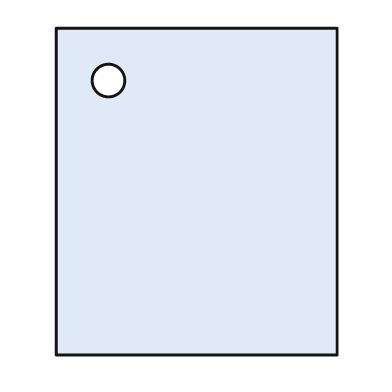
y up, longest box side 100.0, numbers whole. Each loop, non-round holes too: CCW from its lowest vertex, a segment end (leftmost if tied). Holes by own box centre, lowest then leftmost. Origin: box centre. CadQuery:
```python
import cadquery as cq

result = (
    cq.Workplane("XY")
    .moveTo(-43.0, -50.0)
    .lineTo(43.0, -50.0)
    .lineTo(43.0, 50.0)
    .lineTo(-43.0, 50.0)
    .close()
    .moveTo(-27.0, 34.0)
    .circle(5.0)
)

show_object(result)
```